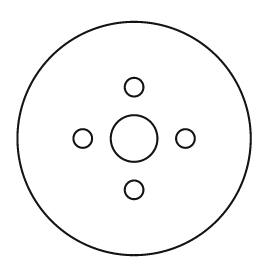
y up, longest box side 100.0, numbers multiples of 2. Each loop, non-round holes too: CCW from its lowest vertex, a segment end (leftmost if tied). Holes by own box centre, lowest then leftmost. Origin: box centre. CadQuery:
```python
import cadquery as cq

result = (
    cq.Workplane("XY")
    .moveTo(0.0, 0.0)
    .circle(50.0)
    .moveTo(0.0, -22.0)
    .circle(4.0)
    .moveTo(-22.0, 0.0)
    .circle(4.0)
    .moveTo(0.0, 0.0)
    .circle(10.0)
    .moveTo(22.0, 0.0)
    .circle(4.0)
    .moveTo(0.0, 22.0)
    .circle(4.0)
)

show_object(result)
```